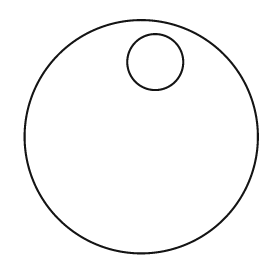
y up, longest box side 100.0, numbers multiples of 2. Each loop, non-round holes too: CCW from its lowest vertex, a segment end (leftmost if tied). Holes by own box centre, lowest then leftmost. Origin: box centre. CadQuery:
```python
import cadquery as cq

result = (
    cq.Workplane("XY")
    .moveTo(0.0, 0.0)
    .circle(50.0)
    .moveTo(6.0, 32.0)
    .circle(12.0)
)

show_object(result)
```